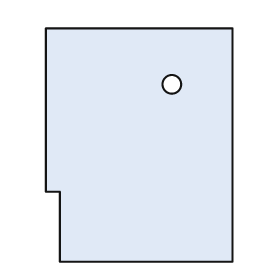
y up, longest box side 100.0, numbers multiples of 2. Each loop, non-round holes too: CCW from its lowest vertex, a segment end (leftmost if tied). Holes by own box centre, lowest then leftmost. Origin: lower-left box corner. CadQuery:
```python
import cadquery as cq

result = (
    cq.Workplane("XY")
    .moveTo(6.0, 0.0)
    .lineTo(80.0, 0.0)
    .lineTo(80.0, 100.0)
    .lineTo(0.0, 100.0)
    .lineTo(0.0, 30.0)
    .lineTo(6.0, 30.0)
    .close()
    .moveTo(54.0, 76.0)
    .circle(4.0)
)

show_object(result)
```